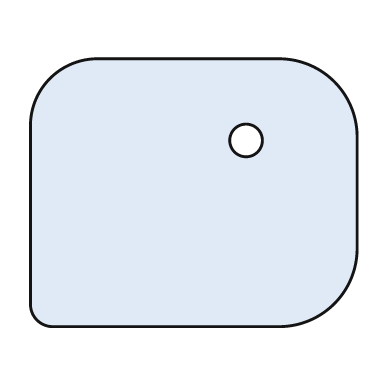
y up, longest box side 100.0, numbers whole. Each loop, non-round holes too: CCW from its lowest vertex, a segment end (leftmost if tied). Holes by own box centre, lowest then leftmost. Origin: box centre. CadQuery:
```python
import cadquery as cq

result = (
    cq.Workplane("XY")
    .moveTo(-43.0, -41.0)
    .lineTo(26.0, -41.0)
    .threePointArc((43.0, -34.0), (50.0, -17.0))
    .lineTo(50.0, 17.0)
    .threePointArc((43.0, 34.0), (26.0, 41.0))
    .lineTo(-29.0, 41.0)
    .threePointArc((-44.0, 35.0), (-50.0, 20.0))
    .lineTo(-50.0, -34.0)
    .threePointArc((-48.0, -39.0), (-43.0, -41.0))
    .close()
    .moveTo(16.0, 16.0)
    .circle(5.0)
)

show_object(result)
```